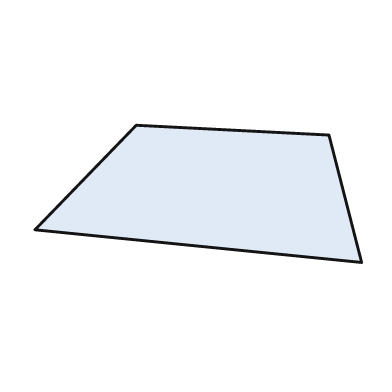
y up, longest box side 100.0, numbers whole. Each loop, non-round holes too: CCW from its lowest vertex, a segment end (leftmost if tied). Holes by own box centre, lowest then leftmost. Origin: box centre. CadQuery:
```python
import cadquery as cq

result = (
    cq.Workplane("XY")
    .moveTo(50.0, -21.0)
    .lineTo(40.0, 18.0)
    .lineTo(-19.0, 21.0)
    .lineTo(-50.0, -11.0)
    .close()
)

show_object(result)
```